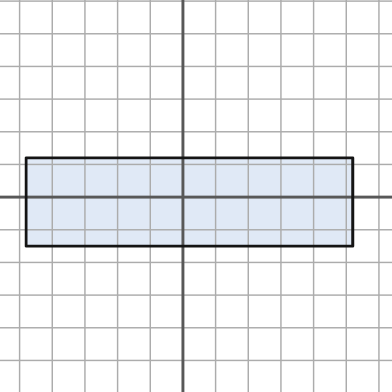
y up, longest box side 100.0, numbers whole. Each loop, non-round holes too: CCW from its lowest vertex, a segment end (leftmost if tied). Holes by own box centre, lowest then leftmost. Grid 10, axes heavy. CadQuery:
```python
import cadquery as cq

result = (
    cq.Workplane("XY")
    .moveTo(-48.0, -15.0)
    .lineTo(52.0, -15.0)
    .lineTo(52.0, 12.0)
    .lineTo(-48.0, 12.0)
    .close()
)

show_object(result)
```